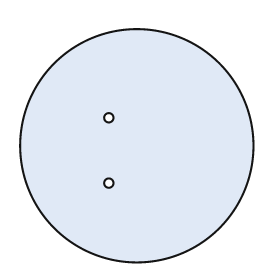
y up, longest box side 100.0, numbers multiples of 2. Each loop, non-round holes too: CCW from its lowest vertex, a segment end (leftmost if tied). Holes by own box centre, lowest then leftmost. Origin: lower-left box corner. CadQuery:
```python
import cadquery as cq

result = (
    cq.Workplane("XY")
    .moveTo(50.0, 50.0)
    .circle(50.0)
    .moveTo(38.0, 34.0)
    .circle(2.0)
    .moveTo(38.0, 62.0)
    .circle(2.0)
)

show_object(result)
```